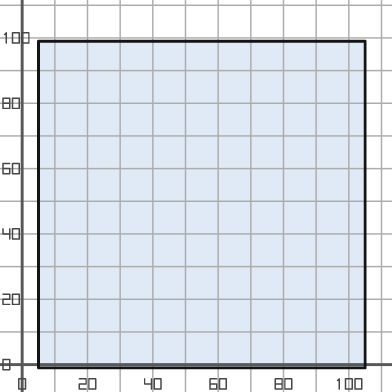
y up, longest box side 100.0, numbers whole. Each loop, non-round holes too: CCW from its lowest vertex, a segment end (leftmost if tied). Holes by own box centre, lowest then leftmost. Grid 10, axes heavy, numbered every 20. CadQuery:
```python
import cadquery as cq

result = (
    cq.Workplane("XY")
    .moveTo(5.0, -1.0)
    .lineTo(105.0, -1.0)
    .lineTo(105.0, 99.0)
    .lineTo(5.0, 99.0)
    .close()
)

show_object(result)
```